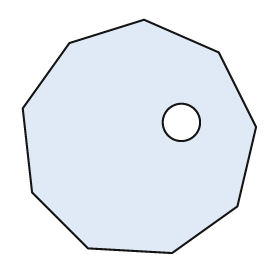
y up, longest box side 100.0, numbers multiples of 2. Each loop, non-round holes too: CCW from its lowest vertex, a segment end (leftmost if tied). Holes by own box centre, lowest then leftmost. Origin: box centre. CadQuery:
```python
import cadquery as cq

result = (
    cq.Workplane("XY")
    .moveTo(14.0, -50.0)
    .lineTo(42.0, -30.0)
    .lineTo(50.0, 4.0)
    .lineTo(34.0, 36.0)
    .lineTo(2.0, 50.0)
    .lineTo(-30.0, 40.0)
    .lineTo(-50.0, 12.0)
    .lineTo(-46.0, -24.0)
    .lineTo(-22.0, -48.0)
    .close()
    .moveTo(18.0, 6.0)
    .circle(8.0)
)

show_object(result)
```